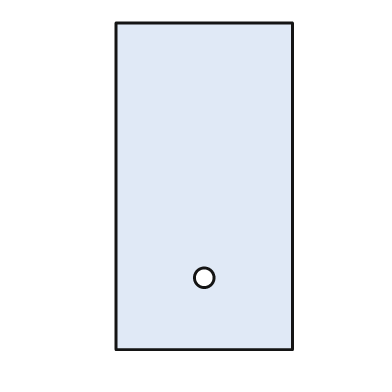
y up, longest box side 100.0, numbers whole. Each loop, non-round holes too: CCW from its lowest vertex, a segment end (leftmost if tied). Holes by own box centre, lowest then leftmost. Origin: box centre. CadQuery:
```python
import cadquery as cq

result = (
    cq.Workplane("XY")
    .moveTo(-27.0, -50.0)
    .lineTo(27.0, -50.0)
    .lineTo(27.0, 50.0)
    .lineTo(-27.0, 50.0)
    .close()
    .moveTo(0.0, -28.0)
    .circle(3.0)
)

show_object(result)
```